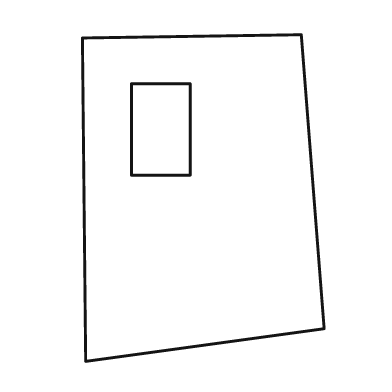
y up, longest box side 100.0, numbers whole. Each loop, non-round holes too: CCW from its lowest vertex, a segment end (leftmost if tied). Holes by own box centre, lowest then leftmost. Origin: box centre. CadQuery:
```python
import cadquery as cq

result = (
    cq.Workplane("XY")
    .moveTo(-36.0, -50.0)
    .lineTo(37.0, -40.0)
    .lineTo(30.0, 50.0)
    .lineTo(-37.0, 49.0)
    .close()
    .moveTo(-22.0, 7.0)
    .lineTo(-4.0, 7.0)
    .lineTo(-4.0, 35.0)
    .lineTo(-22.0, 35.0)
    .close()
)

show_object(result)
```